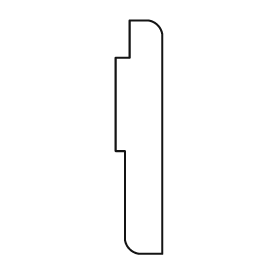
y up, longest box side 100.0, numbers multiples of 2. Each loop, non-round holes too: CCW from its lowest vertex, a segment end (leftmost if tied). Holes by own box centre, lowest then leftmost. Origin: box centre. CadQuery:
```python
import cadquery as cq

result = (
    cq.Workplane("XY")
    .moveTo(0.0, -50.0)
    .lineTo(10.0, -50.0)
    .lineTo(10.0, 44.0)
    .threePointArc((8.0, 48.0), (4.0, 50.0))
    .lineTo(-4.0, 50.0)
    .lineTo(-4.0, 34.0)
    .lineTo(-10.0, 34.0)
    .lineTo(-10.0, -6.0)
    .lineTo(-6.0, -6.0)
    .lineTo(-6.0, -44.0)
    .threePointArc((-4.0, -48.0), (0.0, -50.0))
    .close()
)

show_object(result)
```